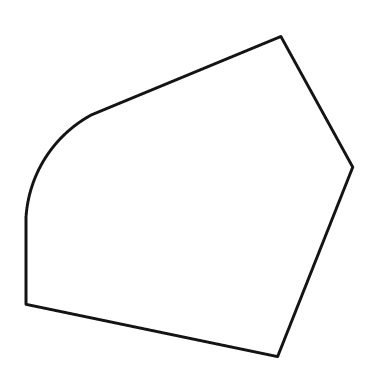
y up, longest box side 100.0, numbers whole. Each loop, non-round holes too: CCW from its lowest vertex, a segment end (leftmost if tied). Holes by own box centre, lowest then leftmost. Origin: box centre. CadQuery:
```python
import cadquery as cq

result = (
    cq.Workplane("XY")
    .moveTo(27.0, -49.0)
    .lineTo(50.0, 9.0)
    .lineTo(28.0, 49.0)
    .lineTo(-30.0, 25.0)
    .threePointArc((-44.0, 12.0), (-50.0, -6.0))
    .lineTo(-50.0, -33.0)
    .close()
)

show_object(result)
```